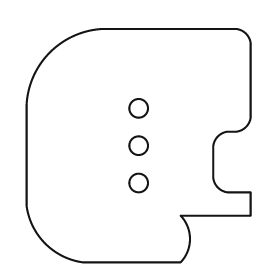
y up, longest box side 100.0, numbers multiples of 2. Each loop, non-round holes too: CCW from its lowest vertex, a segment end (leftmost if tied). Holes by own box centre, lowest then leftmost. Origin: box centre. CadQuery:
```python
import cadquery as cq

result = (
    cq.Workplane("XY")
    .moveTo(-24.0, -50.0)
    .lineTo(18.0, -50.0)
    .threePointArc((22.0, -40.0), (18.0, -30.0))
    .lineTo(48.0, -30.0)
    .lineTo(48.0, -20.0)
    .lineTo(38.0, -20.0)
    .threePointArc((34.0, -18.0), (32.0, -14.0))
    .lineTo(32.0, 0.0)
    .threePointArc((34.0, 4.0), (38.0, 6.0))
    .lineTo(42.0, 6.0)
    .threePointArc((46.0, 8.0), (48.0, 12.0))
    .lineTo(48.0, 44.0)
    .threePointArc((46.0, 48.0), (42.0, 50.0))
    .lineTo(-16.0, 50.0)
    .threePointArc((-38.0, 40.0), (-48.0, 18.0))
    .lineTo(-48.0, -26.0)
    .threePointArc((-40.0, -42.0), (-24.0, -50.0))
    .close()
    .moveTo(0.0, -16.0)
    .circle(4.0)
    .moveTo(0.0, 0.0)
    .circle(4.0)
    .moveTo(0.0, 16.0)
    .circle(4.0)
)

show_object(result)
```